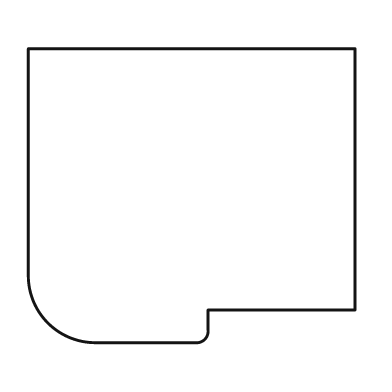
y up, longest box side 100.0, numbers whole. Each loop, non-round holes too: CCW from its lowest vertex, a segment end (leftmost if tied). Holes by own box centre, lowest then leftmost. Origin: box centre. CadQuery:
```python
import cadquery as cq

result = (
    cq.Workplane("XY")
    .moveTo(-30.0, -45.0)
    .lineTo(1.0, -45.0)
    .threePointArc((4.0, -44.0), (5.0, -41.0))
    .lineTo(5.0, -35.0)
    .lineTo(50.0, -35.0)
    .lineTo(50.0, 45.0)
    .lineTo(-50.0, 45.0)
    .lineTo(-50.0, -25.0)
    .threePointArc((-44.0, -39.0), (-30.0, -45.0))
    .close()
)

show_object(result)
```